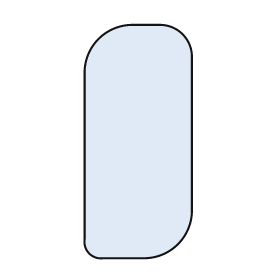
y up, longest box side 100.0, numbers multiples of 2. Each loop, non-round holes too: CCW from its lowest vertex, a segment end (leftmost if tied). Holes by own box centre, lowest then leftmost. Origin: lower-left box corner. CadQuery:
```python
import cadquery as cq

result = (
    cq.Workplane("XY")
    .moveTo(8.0, 0.0)
    .lineTo(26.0, 0.0)
    .threePointArc((40.0, 6.0), (46.0, 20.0))
    .lineTo(46.0, 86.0)
    .threePointArc((42.0, 96.0), (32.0, 100.0))
    .lineTo(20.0, 100.0)
    .threePointArc((6.0, 94.0), (0.0, 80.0))
    .lineTo(0.0, 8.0)
    .threePointArc((2.0, 2.0), (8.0, 0.0))
    .close()
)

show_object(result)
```